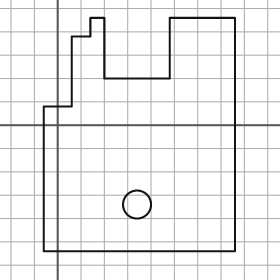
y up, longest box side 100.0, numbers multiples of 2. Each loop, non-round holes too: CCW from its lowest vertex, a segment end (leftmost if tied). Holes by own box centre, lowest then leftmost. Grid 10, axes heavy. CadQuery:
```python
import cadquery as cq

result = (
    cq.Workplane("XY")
    .moveTo(-6.0, -54.0)
    .lineTo(76.0, -54.0)
    .lineTo(76.0, 46.0)
    .lineTo(48.0, 46.0)
    .lineTo(48.0, 20.0)
    .lineTo(20.0, 20.0)
    .lineTo(20.0, 46.0)
    .lineTo(14.0, 46.0)
    .lineTo(14.0, 38.0)
    .lineTo(6.0, 38.0)
    .lineTo(6.0, 8.0)
    .lineTo(-6.0, 8.0)
    .close()
    .moveTo(34.0, -34.0)
    .circle(6.0)
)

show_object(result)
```